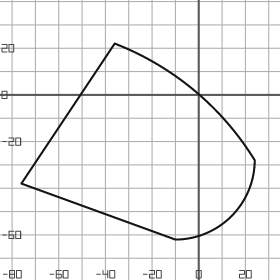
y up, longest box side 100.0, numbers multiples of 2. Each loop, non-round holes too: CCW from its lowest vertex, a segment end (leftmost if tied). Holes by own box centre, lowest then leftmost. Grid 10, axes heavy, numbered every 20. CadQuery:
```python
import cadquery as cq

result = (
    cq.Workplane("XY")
    .moveTo(-10.0, -62.0)
    .threePointArc((14.0, -52.0), (24.0, -28.0))
    .threePointArc((-2.0, 2.0), (-36.0, 22.0))
    .lineTo(-76.0, -38.0)
    .close()
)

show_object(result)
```